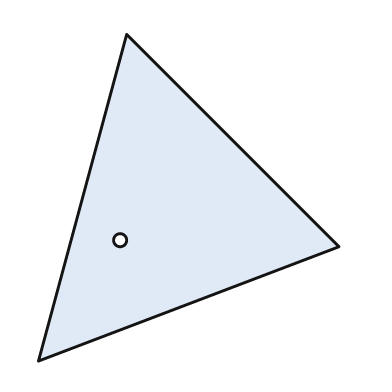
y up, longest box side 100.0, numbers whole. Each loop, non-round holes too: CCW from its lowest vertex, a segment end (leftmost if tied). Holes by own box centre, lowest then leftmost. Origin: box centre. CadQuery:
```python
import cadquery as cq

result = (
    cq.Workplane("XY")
    .moveTo(-46.0, -50.0)
    .lineTo(46.0, -15.0)
    .lineTo(-19.0, 50.0)
    .close()
    .moveTo(-21.0, -13.0)
    .circle(2.0)
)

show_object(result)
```